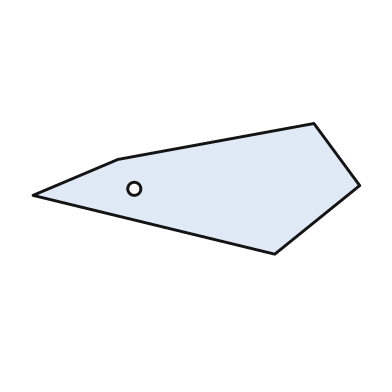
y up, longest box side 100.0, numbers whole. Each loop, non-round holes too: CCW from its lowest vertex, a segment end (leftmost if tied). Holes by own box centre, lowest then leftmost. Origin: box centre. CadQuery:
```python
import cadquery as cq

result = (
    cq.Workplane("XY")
    .moveTo(24.0, -20.0)
    .lineTo(50.0, 1.0)
    .lineTo(36.0, 20.0)
    .lineTo(-24.0, 9.0)
    .lineTo(-50.0, -2.0)
    .close()
    .moveTo(-19.0, 0.0)
    .circle(2.0)
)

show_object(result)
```